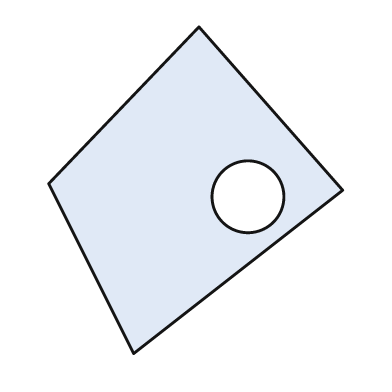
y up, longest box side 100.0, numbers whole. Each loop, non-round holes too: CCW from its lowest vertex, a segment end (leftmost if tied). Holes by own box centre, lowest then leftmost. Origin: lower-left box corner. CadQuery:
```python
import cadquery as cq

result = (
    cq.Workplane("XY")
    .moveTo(26.0, 0.0)
    .lineTo(90.0, 50.0)
    .lineTo(46.0, 100.0)
    .lineTo(0.0, 52.0)
    .close()
    .moveTo(61.0, 48.0)
    .circle(11.0)
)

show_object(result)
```